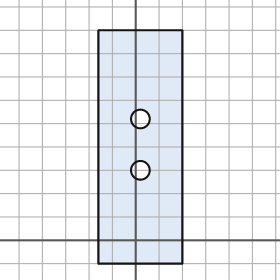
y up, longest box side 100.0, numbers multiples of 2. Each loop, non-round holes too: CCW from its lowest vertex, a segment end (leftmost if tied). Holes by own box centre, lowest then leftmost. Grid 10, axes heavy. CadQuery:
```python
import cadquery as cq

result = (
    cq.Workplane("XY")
    .moveTo(-16.0, -10.0)
    .lineTo(20.0, -10.0)
    .lineTo(20.0, 90.0)
    .lineTo(-16.0, 90.0)
    .close()
    .moveTo(2.0, 30.0)
    .circle(4.0)
    .moveTo(2.0, 52.0)
    .circle(4.0)
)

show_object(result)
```